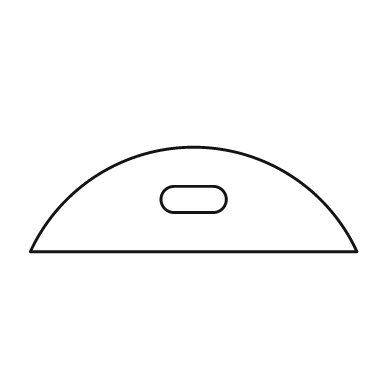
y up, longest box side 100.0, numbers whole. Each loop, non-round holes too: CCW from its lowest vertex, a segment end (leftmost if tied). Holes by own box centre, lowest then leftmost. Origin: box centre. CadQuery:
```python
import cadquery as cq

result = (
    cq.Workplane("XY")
    .moveTo(-50.0, -16.0)
    .lineTo(50.0, -16.0)
    .threePointArc((0.0, 16.0), (-50.0, -16.0))
    .close()
    .moveTo(-6.0, -4.0)
    .lineTo(6.0, -4.0)
    .threePointArc((10.0, 0.0), (6.0, 4.0))
    .lineTo(-6.0, 4.0)
    .threePointArc((-10.0, 0.0), (-6.0, -4.0))
    .close()
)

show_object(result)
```